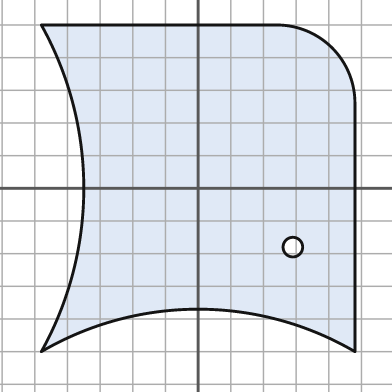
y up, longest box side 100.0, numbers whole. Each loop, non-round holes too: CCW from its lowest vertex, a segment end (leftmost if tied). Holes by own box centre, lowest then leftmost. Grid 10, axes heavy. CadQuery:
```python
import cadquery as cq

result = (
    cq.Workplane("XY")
    .moveTo(-48.0, -50.0)
    .threePointArc((0.0, -37.0), (48.0, -50.0))
    .lineTo(48.0, 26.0)
    .threePointArc((41.0, 43.0), (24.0, 50.0))
    .lineTo(-48.0, 50.0)
    .threePointArc((-35.0, 0.0), (-48.0, -50.0))
    .close()
    .moveTo(29.0, -18.0)
    .circle(3.0)
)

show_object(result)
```